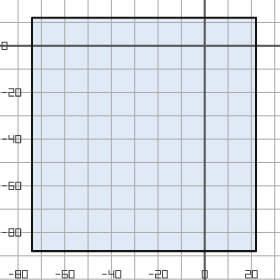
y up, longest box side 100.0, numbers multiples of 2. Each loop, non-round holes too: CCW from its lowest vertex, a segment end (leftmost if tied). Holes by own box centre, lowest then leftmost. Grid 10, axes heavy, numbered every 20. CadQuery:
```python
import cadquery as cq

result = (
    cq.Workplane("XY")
    .moveTo(-74.0, -88.0)
    .lineTo(22.0, -88.0)
    .lineTo(22.0, 12.0)
    .lineTo(-74.0, 12.0)
    .close()
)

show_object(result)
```